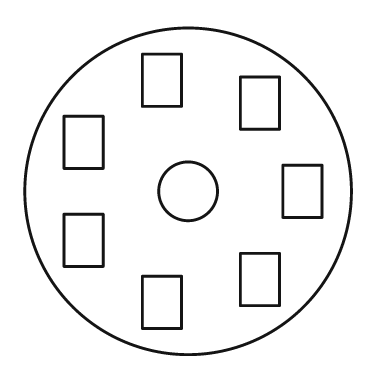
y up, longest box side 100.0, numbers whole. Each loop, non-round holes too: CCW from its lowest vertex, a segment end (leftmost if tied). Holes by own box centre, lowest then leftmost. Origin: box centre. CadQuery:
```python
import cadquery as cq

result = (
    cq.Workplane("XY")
    .moveTo(0.0, 0.0)
    .circle(50.0)
    .moveTo(-14.0, -42.0)
    .lineTo(-2.0, -42.0)
    .lineTo(-2.0, -26.0)
    .lineTo(-14.0, -26.0)
    .close()
    .moveTo(16.0, -35.0)
    .lineTo(28.0, -35.0)
    .lineTo(28.0, -19.0)
    .lineTo(16.0, -19.0)
    .close()
    .moveTo(-38.0, -23.0)
    .lineTo(-26.0, -23.0)
    .lineTo(-26.0, -7.0)
    .lineTo(-38.0, -7.0)
    .close()
    .moveTo(0.0, 0.0)
    .circle(9.0)
    .moveTo(29.0, -8.0)
    .lineTo(41.0, -8.0)
    .lineTo(41.0, 8.0)
    .lineTo(29.0, 8.0)
    .close()
    .moveTo(-38.0, 7.0)
    .lineTo(-26.0, 7.0)
    .lineTo(-26.0, 23.0)
    .lineTo(-38.0, 23.0)
    .close()
    .moveTo(16.0, 19.0)
    .lineTo(28.0, 19.0)
    .lineTo(28.0, 35.0)
    .lineTo(16.0, 35.0)
    .close()
    .moveTo(-14.0, 26.0)
    .lineTo(-2.0, 26.0)
    .lineTo(-2.0, 42.0)
    .lineTo(-14.0, 42.0)
    .close()
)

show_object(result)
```